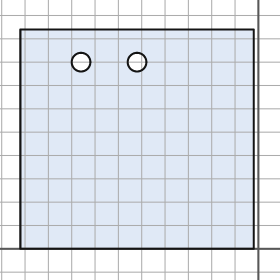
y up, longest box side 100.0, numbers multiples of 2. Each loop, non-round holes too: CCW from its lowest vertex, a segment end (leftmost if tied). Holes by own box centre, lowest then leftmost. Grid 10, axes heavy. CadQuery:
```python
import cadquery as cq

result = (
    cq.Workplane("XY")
    .moveTo(-102.0, 0.0)
    .lineTo(-2.0, 0.0)
    .lineTo(-2.0, 94.0)
    .lineTo(-102.0, 94.0)
    .close()
    .moveTo(-76.0, 80.0)
    .circle(4.0)
    .moveTo(-52.0, 80.0)
    .circle(4.0)
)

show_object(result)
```